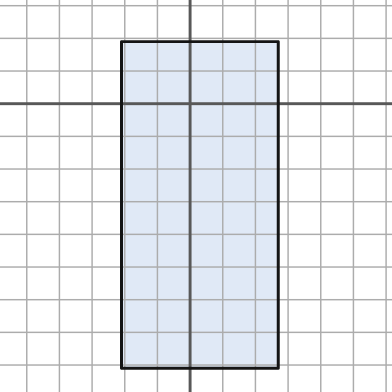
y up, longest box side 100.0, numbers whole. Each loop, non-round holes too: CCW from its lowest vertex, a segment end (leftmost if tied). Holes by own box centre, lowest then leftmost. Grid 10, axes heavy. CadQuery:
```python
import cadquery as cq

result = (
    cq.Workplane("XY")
    .moveTo(-21.0, -81.0)
    .lineTo(27.0, -81.0)
    .lineTo(27.0, 19.0)
    .lineTo(-21.0, 19.0)
    .close()
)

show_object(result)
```